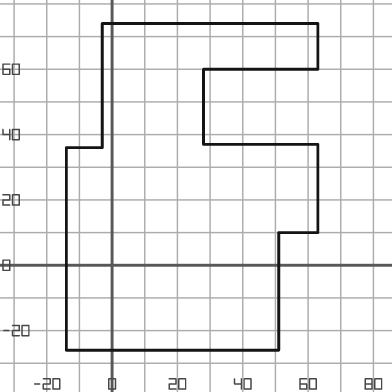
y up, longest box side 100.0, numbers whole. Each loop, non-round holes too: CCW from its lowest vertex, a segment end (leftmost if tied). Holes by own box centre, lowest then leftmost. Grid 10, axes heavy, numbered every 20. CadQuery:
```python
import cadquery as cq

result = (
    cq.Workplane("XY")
    .moveTo(-14.0, -26.0)
    .lineTo(51.0, -26.0)
    .lineTo(51.0, 10.0)
    .lineTo(63.0, 10.0)
    .lineTo(63.0, 37.0)
    .lineTo(28.0, 37.0)
    .lineTo(28.0, 60.0)
    .lineTo(63.0, 60.0)
    .lineTo(63.0, 74.0)
    .lineTo(-3.0, 74.0)
    .lineTo(-3.0, 36.0)
    .lineTo(-14.0, 36.0)
    .close()
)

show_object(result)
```